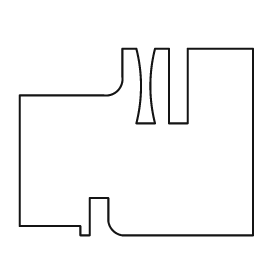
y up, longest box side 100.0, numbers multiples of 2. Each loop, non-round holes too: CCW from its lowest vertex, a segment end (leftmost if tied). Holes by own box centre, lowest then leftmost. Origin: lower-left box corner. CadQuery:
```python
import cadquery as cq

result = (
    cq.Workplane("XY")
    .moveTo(26.0, 0.0)
    .lineTo(30.0, 0.0)
    .lineTo(30.0, 16.0)
    .lineTo(38.0, 16.0)
    .lineTo(38.0, 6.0)
    .threePointArc((40.0, 2.0), (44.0, 0.0))
    .lineTo(100.0, 0.0)
    .lineTo(100.0, 80.0)
    .lineTo(72.0, 80.0)
    .lineTo(72.0, 48.0)
    .lineTo(64.0, 48.0)
    .lineTo(64.0, 80.0)
    .lineTo(58.0, 80.0)
    .threePointArc((56.0, 64.0), (58.0, 48.0))
    .lineTo(50.0, 48.0)
    .threePointArc((52.0, 64.0), (50.0, 80.0))
    .lineTo(44.0, 80.0)
    .lineTo(44.0, 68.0)
    .threePointArc((42.0, 62.0), (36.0, 60.0))
    .lineTo(0.0, 60.0)
    .lineTo(0.0, 4.0)
    .lineTo(26.0, 4.0)
    .close()
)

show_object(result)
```